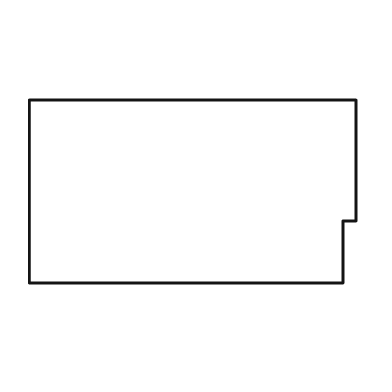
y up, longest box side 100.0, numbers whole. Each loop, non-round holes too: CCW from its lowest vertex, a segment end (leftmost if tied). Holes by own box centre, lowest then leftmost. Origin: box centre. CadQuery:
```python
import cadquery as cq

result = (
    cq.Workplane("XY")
    .moveTo(-50.0, -28.0)
    .lineTo(46.0, -28.0)
    .lineTo(46.0, -9.0)
    .lineTo(50.0, -9.0)
    .lineTo(50.0, 28.0)
    .lineTo(-50.0, 28.0)
    .close()
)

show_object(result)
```